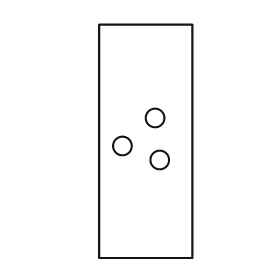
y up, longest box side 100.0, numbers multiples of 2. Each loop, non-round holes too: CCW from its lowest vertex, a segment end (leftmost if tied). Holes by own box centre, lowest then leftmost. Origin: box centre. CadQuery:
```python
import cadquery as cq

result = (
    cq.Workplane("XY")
    .moveTo(-20.0, -50.0)
    .lineTo(20.0, -50.0)
    .lineTo(20.0, 50.0)
    .lineTo(-20.0, 50.0)
    .close()
    .moveTo(6.0, -8.0)
    .circle(4.0)
    .moveTo(-10.0, -2.0)
    .circle(4.0)
    .moveTo(4.0, 10.0)
    .circle(4.0)
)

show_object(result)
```